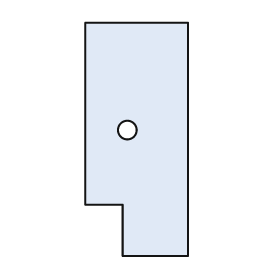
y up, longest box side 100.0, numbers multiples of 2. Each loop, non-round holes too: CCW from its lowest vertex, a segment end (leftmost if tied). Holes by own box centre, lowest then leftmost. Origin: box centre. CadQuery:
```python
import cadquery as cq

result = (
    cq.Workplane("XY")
    .moveTo(-6.0, -50.0)
    .lineTo(22.0, -50.0)
    .lineTo(22.0, 50.0)
    .lineTo(-22.0, 50.0)
    .lineTo(-22.0, -28.0)
    .lineTo(-6.0, -28.0)
    .close()
    .moveTo(-4.0, 4.0)
    .circle(4.0)
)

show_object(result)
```